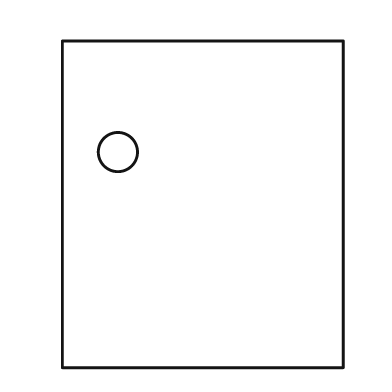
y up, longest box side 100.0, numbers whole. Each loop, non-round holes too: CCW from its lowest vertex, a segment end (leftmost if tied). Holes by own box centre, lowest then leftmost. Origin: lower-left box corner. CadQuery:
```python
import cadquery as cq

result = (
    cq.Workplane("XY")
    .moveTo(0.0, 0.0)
    .lineTo(86.0, 0.0)
    .lineTo(86.0, 100.0)
    .lineTo(0.0, 100.0)
    .close()
    .moveTo(17.0, 66.0)
    .circle(6.0)
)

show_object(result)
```